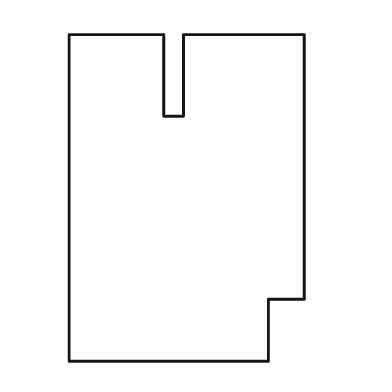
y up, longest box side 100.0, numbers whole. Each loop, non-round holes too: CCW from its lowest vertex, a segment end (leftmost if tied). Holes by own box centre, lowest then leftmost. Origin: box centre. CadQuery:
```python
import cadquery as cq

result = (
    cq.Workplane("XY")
    .moveTo(-36.0, -50.0)
    .lineTo(25.0, -50.0)
    .lineTo(25.0, -31.0)
    .lineTo(36.0, -31.0)
    .lineTo(36.0, 50.0)
    .lineTo(-1.0, 50.0)
    .lineTo(-1.0, 25.0)
    .lineTo(-7.0, 25.0)
    .lineTo(-7.0, 50.0)
    .lineTo(-36.0, 50.0)
    .close()
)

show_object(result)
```